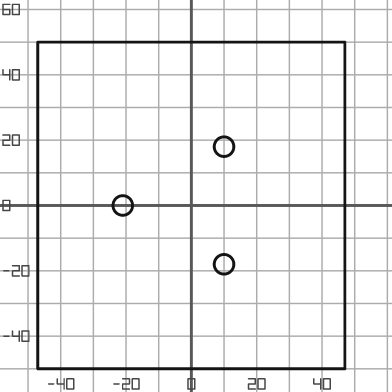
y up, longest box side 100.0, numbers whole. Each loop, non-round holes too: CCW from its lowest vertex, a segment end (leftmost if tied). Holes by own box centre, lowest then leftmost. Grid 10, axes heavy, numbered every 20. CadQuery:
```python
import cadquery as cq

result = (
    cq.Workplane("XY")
    .moveTo(-47.0, -50.0)
    .lineTo(47.0, -50.0)
    .lineTo(47.0, 50.0)
    .lineTo(-47.0, 50.0)
    .close()
    .moveTo(10.0, -18.0)
    .circle(3.0)
    .moveTo(-21.0, 0.0)
    .circle(3.0)
    .moveTo(10.0, 18.0)
    .circle(3.0)
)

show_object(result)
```